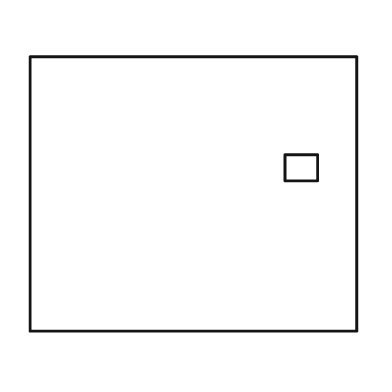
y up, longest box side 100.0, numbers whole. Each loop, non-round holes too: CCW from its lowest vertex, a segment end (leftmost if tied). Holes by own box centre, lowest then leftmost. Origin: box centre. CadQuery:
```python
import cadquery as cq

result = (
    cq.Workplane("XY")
    .moveTo(-50.0, -42.0)
    .lineTo(50.0, -42.0)
    .lineTo(50.0, 42.0)
    .lineTo(-50.0, 42.0)
    .close()
    .moveTo(28.0, 4.0)
    .lineTo(38.0, 4.0)
    .lineTo(38.0, 12.0)
    .lineTo(28.0, 12.0)
    .close()
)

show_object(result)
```